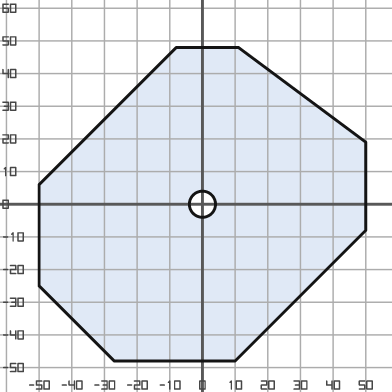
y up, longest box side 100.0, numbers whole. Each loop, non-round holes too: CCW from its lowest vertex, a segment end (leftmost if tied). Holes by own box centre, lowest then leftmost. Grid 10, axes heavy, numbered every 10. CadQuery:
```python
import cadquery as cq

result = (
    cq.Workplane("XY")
    .moveTo(-27.0, -48.0)
    .lineTo(10.0, -48.0)
    .lineTo(50.0, -8.0)
    .lineTo(50.0, 19.0)
    .lineTo(11.0, 48.0)
    .lineTo(-8.0, 48.0)
    .lineTo(-50.0, 6.0)
    .lineTo(-50.0, -25.0)
    .close()
    .moveTo(0.0, 0.0)
    .circle(4.0)
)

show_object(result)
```